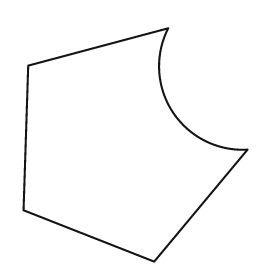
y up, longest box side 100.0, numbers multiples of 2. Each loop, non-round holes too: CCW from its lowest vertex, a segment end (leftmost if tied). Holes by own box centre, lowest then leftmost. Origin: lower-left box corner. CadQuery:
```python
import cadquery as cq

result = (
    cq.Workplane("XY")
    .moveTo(56.0, 0.0)
    .lineTo(96.0, 48.0)
    .threePointArc((64.0, 64.0), (62.0, 100.0))
    .lineTo(2.0, 84.0)
    .lineTo(0.0, 22.0)
    .close()
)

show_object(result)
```